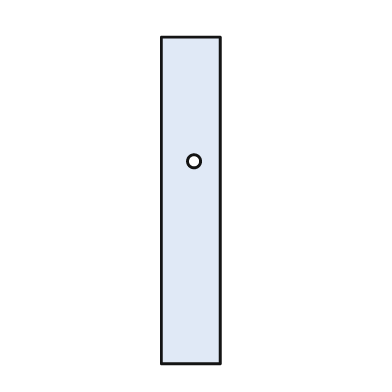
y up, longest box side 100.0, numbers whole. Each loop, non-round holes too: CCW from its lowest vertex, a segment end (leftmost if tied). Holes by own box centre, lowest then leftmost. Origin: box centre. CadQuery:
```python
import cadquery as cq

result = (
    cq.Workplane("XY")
    .moveTo(-9.0, -50.0)
    .lineTo(9.0, -50.0)
    .lineTo(9.0, 50.0)
    .lineTo(-9.0, 50.0)
    .close()
    .moveTo(1.0, 12.0)
    .circle(2.0)
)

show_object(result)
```